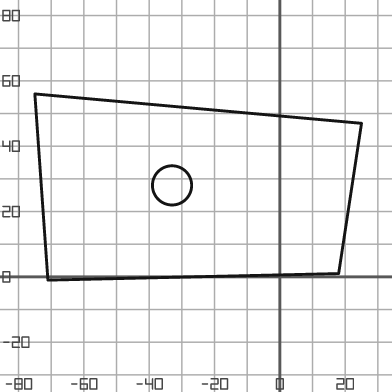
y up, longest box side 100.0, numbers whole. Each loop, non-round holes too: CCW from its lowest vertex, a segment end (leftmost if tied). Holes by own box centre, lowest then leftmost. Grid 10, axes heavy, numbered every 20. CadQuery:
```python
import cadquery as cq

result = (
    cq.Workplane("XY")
    .moveTo(-71.0, -1.0)
    .lineTo(18.0, 1.0)
    .lineTo(25.0, 47.0)
    .lineTo(-75.0, 56.0)
    .close()
    .moveTo(-33.0, 28.0)
    .circle(6.0)
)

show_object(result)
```